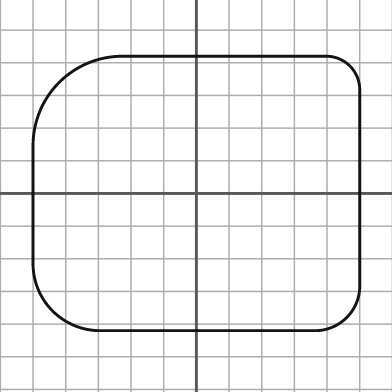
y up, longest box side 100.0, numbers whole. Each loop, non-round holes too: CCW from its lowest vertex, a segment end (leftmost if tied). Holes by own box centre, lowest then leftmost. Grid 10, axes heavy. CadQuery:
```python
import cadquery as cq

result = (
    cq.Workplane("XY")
    .moveTo(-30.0, -42.0)
    .lineTo(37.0, -42.0)
    .threePointArc((46.0, -38.0), (50.0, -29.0))
    .lineTo(50.0, 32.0)
    .threePointArc((47.0, 39.0), (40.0, 42.0))
    .lineTo(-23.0, 42.0)
    .threePointArc((-42.0, 34.0), (-50.0, 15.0))
    .lineTo(-50.0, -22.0)
    .threePointArc((-44.0, -36.0), (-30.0, -42.0))
    .close()
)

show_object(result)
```